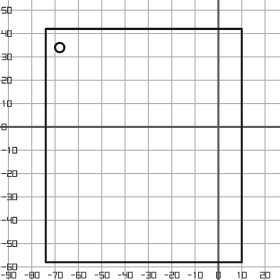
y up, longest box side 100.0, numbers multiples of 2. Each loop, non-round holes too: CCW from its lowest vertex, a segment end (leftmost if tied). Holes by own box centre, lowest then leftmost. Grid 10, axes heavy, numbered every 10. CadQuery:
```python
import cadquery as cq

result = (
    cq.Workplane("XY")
    .moveTo(-74.0, -58.0)
    .lineTo(10.0, -58.0)
    .lineTo(10.0, 42.0)
    .lineTo(-74.0, 42.0)
    .close()
    .moveTo(-68.0, 34.0)
    .circle(2.0)
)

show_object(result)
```